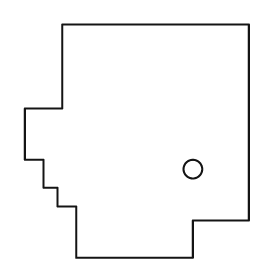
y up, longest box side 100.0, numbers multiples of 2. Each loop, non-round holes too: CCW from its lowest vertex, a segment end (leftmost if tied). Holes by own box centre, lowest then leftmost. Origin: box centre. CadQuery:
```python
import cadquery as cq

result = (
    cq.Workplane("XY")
    .moveTo(-26.0, -50.0)
    .lineTo(24.0, -50.0)
    .lineTo(24.0, -34.0)
    .lineTo(48.0, -34.0)
    .lineTo(48.0, 50.0)
    .lineTo(-32.0, 50.0)
    .lineTo(-32.0, 14.0)
    .lineTo(-48.0, 14.0)
    .lineTo(-48.0, -8.0)
    .lineTo(-40.0, -8.0)
    .lineTo(-40.0, -20.0)
    .lineTo(-34.0, -20.0)
    .lineTo(-34.0, -28.0)
    .lineTo(-26.0, -28.0)
    .close()
    .moveTo(24.0, -12.0)
    .circle(4.0)
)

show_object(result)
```